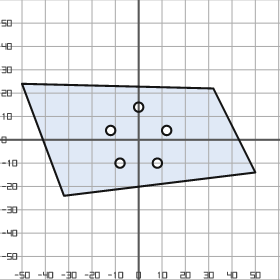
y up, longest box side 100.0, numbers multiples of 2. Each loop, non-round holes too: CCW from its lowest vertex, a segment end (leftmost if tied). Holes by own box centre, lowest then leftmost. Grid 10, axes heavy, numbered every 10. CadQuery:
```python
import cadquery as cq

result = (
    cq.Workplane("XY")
    .moveTo(-32.0, -24.0)
    .lineTo(50.0, -14.0)
    .lineTo(32.0, 22.0)
    .lineTo(-50.0, 24.0)
    .close()
    .moveTo(-8.0, -10.0)
    .circle(2.0)
    .moveTo(8.0, -10.0)
    .circle(2.0)
    .moveTo(-12.0, 4.0)
    .circle(2.0)
    .moveTo(12.0, 4.0)
    .circle(2.0)
    .moveTo(0.0, 14.0)
    .circle(2.0)
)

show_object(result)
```